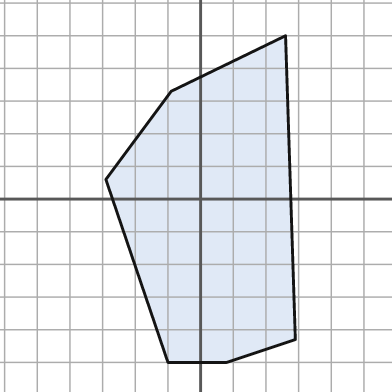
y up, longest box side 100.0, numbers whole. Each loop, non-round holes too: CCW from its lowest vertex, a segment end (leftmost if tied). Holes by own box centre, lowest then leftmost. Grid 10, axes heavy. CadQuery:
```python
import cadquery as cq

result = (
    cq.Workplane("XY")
    .moveTo(-10.0, -50.0)
    .lineTo(8.0, -50.0)
    .lineTo(29.0, -43.0)
    .lineTo(26.0, 50.0)
    .lineTo(-9.0, 33.0)
    .lineTo(-29.0, 6.0)
    .close()
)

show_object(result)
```